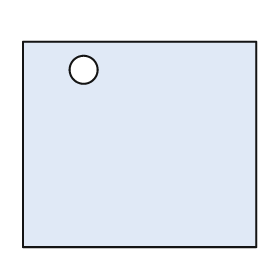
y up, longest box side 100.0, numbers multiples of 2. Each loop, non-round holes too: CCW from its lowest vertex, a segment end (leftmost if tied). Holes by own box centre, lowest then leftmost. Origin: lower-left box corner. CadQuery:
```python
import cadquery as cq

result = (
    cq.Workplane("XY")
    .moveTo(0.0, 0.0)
    .lineTo(100.0, 0.0)
    .lineTo(100.0, 88.0)
    .lineTo(0.0, 88.0)
    .close()
    .moveTo(26.0, 76.0)
    .circle(6.0)
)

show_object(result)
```